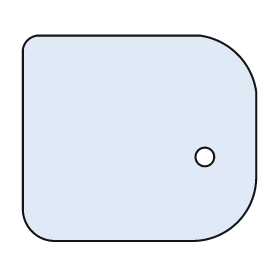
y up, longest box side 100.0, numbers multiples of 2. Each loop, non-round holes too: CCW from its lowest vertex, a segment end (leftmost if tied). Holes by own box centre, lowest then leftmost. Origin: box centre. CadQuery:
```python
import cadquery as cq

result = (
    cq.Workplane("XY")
    .moveTo(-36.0, -44.0)
    .lineTo(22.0, -44.0)
    .threePointArc((42.0, -36.0), (50.0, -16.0))
    .lineTo(50.0, 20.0)
    .threePointArc((42.0, 36.0), (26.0, 44.0))
    .lineTo(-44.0, 44.0)
    .threePointArc((-48.0, 42.0), (-50.0, 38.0))
    .lineTo(-50.0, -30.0)
    .threePointArc((-46.0, -40.0), (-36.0, -44.0))
    .close()
    .moveTo(28.0, -8.0)
    .circle(4.0)
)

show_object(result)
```